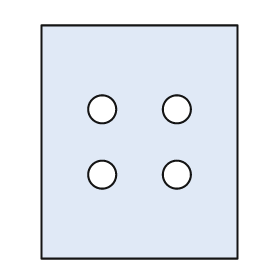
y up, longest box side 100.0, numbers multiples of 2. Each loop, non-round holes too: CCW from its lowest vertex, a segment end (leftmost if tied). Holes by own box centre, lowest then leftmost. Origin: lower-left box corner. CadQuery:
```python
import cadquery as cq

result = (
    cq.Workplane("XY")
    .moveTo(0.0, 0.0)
    .lineTo(84.0, 0.0)
    .lineTo(84.0, 100.0)
    .lineTo(0.0, 100.0)
    .close()
    .moveTo(26.0, 36.0)
    .circle(6.0)
    .moveTo(58.0, 36.0)
    .circle(6.0)
    .moveTo(26.0, 64.0)
    .circle(6.0)
    .moveTo(58.0, 64.0)
    .circle(6.0)
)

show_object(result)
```